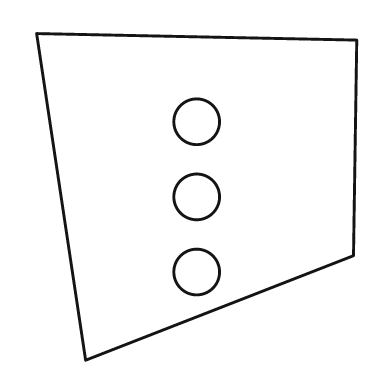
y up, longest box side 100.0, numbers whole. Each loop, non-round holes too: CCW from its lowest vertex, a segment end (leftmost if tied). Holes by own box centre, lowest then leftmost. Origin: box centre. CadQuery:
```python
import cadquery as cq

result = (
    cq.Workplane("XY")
    .moveTo(-34.0, -50.0)
    .lineTo(48.0, -18.0)
    .lineTo(49.0, 48.0)
    .lineTo(-49.0, 50.0)
    .close()
    .moveTo(0.0, -23.0)
    .circle(7.0)
    .moveTo(0.0, 0.0)
    .circle(7.0)
    .moveTo(0.0, 23.0)
    .circle(7.0)
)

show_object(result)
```